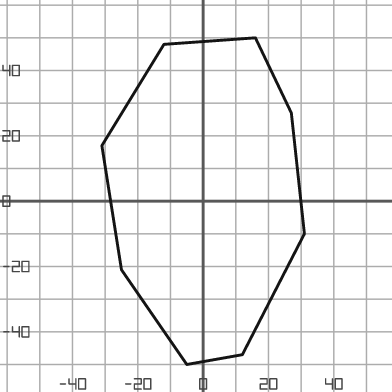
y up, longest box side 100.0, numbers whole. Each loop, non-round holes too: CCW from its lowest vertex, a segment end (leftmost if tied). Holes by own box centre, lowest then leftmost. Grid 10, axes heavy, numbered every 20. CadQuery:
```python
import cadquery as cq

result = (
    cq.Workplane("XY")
    .moveTo(-5.0, -50.0)
    .lineTo(12.0, -47.0)
    .lineTo(31.0, -10.0)
    .lineTo(27.0, 27.0)
    .lineTo(16.0, 50.0)
    .lineTo(-12.0, 48.0)
    .lineTo(-31.0, 17.0)
    .lineTo(-25.0, -21.0)
    .close()
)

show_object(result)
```